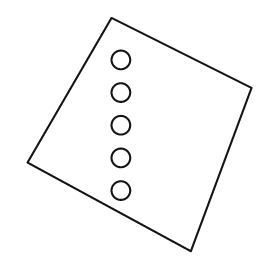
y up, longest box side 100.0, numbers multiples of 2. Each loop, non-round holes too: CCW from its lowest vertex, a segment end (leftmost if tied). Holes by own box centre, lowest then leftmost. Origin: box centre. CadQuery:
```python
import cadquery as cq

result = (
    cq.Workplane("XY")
    .moveTo(22.0, -50.0)
    .lineTo(48.0, 20.0)
    .lineTo(-12.0, 50.0)
    .lineTo(-48.0, -12.0)
    .close()
    .moveTo(-8.0, -24.0)
    .circle(4.0)
    .moveTo(-8.0, -10.0)
    .circle(4.0)
    .moveTo(-8.0, 4.0)
    .circle(4.0)
    .moveTo(-8.0, 18.0)
    .circle(4.0)
    .moveTo(-8.0, 32.0)
    .circle(4.0)
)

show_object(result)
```